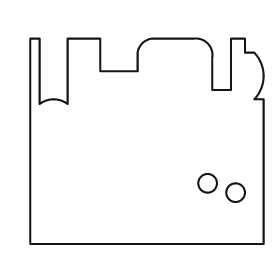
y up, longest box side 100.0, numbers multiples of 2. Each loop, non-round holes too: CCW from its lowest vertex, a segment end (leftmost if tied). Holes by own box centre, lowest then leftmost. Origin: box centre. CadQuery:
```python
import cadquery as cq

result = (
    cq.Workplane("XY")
    .moveTo(-50.0, -44.0)
    .lineTo(50.0, -44.0)
    .lineTo(50.0, 18.0)
    .lineTo(46.0, 18.0)
    .threePointArc((50.0, 28.0), (46.0, 38.0))
    .lineTo(42.0, 38.0)
    .lineTo(42.0, 44.0)
    .lineTo(36.0, 44.0)
    .lineTo(36.0, 22.0)
    .lineTo(28.0, 22.0)
    .lineTo(28.0, 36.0)
    .threePointArc((26.0, 42.0), (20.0, 44.0))
    .lineTo(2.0, 44.0)
    .threePointArc((-2.0, 42.0), (-4.0, 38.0))
    .lineTo(-4.0, 30.0)
    .lineTo(-20.0, 30.0)
    .lineTo(-20.0, 44.0)
    .lineTo(-34.0, 44.0)
    .lineTo(-34.0, 16.0)
    .threePointArc((-40.0, 18.0), (-46.0, 16.0))
    .lineTo(-46.0, 44.0)
    .lineTo(-50.0, 44.0)
    .close()
    .moveTo(38.0, -22.0)
    .circle(4.0)
    .moveTo(26.0, -18.0)
    .circle(4.0)
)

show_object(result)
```